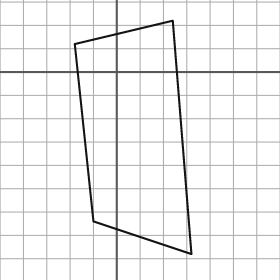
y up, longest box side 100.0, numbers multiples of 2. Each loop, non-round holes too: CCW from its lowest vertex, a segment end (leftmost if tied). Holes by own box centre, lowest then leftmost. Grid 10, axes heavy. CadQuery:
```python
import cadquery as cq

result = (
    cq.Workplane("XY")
    .moveTo(32.0, -78.0)
    .lineTo(24.0, 22.0)
    .lineTo(-18.0, 12.0)
    .lineTo(-10.0, -64.0)
    .close()
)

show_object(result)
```